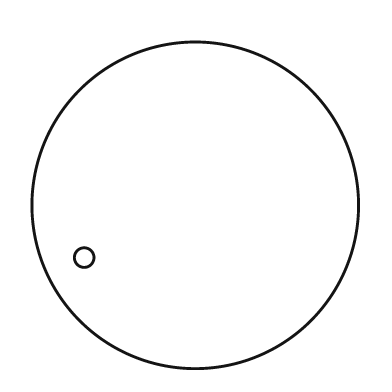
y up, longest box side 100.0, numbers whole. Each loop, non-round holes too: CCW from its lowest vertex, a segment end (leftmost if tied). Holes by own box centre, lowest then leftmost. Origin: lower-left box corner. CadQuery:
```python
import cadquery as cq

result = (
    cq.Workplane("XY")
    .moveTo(50.0, 50.0)
    .circle(50.0)
    .moveTo(16.0, 34.0)
    .circle(3.0)
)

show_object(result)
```